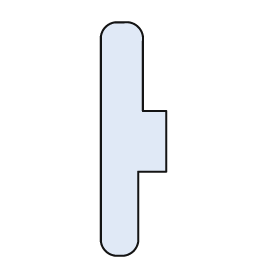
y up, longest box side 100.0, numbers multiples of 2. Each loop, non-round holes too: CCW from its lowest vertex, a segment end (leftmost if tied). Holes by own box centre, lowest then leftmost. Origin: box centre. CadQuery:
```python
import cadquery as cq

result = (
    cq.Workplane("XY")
    .moveTo(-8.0, -50.0)
    .lineTo(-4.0, -50.0)
    .threePointArc((0.0, -48.0), (2.0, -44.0))
    .lineTo(2.0, -14.0)
    .lineTo(14.0, -14.0)
    .lineTo(14.0, 12.0)
    .lineTo(4.0, 12.0)
    .lineTo(4.0, 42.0)
    .threePointArc((2.0, 48.0), (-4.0, 50.0))
    .lineTo(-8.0, 50.0)
    .threePointArc((-12.0, 48.0), (-14.0, 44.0))
    .lineTo(-14.0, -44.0)
    .threePointArc((-12.0, -48.0), (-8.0, -50.0))
    .close()
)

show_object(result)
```